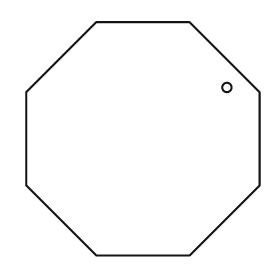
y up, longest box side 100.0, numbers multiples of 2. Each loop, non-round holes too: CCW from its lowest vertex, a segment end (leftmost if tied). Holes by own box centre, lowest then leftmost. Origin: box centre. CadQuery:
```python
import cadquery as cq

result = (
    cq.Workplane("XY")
    .moveTo(-20.0, -50.0)
    .lineTo(20.0, -50.0)
    .lineTo(50.0, -20.0)
    .lineTo(50.0, 20.0)
    .lineTo(20.0, 50.0)
    .lineTo(-20.0, 50.0)
    .lineTo(-50.0, 20.0)
    .lineTo(-50.0, -20.0)
    .close()
    .moveTo(36.0, 22.0)
    .circle(2.0)
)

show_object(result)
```